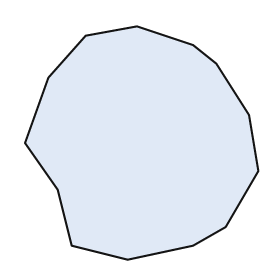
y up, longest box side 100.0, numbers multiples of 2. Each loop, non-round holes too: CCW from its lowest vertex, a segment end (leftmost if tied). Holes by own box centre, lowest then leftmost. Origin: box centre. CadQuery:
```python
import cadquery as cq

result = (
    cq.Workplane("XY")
    .moveTo(-6.0, -50.0)
    .lineTo(22.0, -44.0)
    .lineTo(36.0, -36.0)
    .lineTo(50.0, -12.0)
    .lineTo(46.0, 12.0)
    .lineTo(32.0, 34.0)
    .lineTo(22.0, 42.0)
    .lineTo(-2.0, 50.0)
    .lineTo(-24.0, 46.0)
    .lineTo(-40.0, 28.0)
    .lineTo(-50.0, 0.0)
    .lineTo(-36.0, -20.0)
    .lineTo(-30.0, -44.0)
    .close()
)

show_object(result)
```